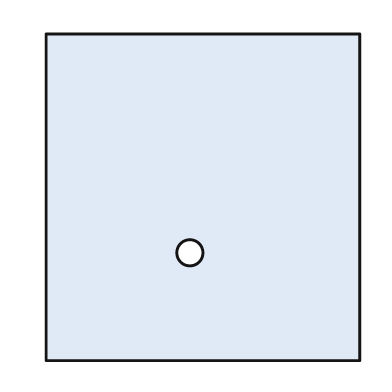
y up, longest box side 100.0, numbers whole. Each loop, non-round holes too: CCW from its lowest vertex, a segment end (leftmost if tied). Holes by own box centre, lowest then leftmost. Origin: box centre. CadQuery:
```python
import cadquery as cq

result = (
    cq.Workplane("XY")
    .moveTo(-48.0, -50.0)
    .lineTo(48.0, -50.0)
    .lineTo(48.0, 50.0)
    .lineTo(-48.0, 50.0)
    .close()
    .moveTo(-4.0, -17.0)
    .circle(4.0)
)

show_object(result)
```